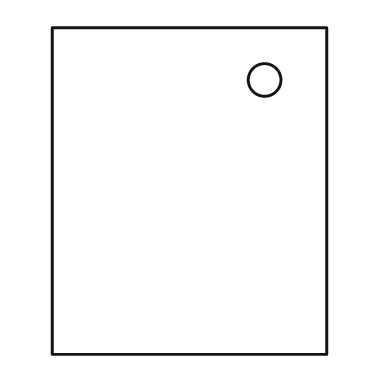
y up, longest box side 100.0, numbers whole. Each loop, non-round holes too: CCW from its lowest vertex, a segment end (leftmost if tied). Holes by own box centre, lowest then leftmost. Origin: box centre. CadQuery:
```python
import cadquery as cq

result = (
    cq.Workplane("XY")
    .moveTo(-42.0, -50.0)
    .lineTo(42.0, -50.0)
    .lineTo(42.0, 50.0)
    .lineTo(-42.0, 50.0)
    .close()
    .moveTo(23.0, 34.0)
    .circle(5.0)
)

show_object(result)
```